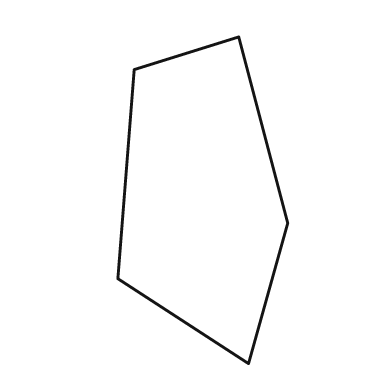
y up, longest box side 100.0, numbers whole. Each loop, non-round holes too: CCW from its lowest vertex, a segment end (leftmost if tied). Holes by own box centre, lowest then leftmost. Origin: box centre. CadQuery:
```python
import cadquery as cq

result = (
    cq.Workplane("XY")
    .moveTo(14.0, -50.0)
    .lineTo(26.0, -7.0)
    .lineTo(11.0, 50.0)
    .lineTo(-21.0, 40.0)
    .lineTo(-26.0, -24.0)
    .close()
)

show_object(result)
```